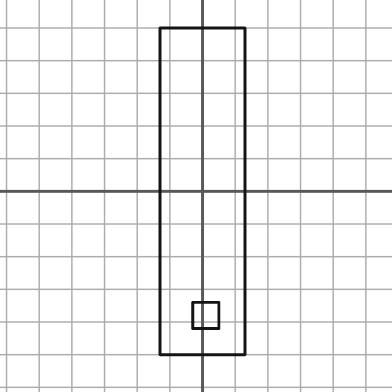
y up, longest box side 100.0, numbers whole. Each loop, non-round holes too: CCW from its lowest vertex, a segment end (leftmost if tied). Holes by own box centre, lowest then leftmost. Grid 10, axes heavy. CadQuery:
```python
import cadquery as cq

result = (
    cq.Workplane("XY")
    .moveTo(-13.0, -50.0)
    .lineTo(13.0, -50.0)
    .lineTo(13.0, 50.0)
    .lineTo(-13.0, 50.0)
    .close()
    .moveTo(-3.0, -42.0)
    .lineTo(5.0, -42.0)
    .lineTo(5.0, -34.0)
    .lineTo(-3.0, -34.0)
    .close()
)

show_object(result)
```